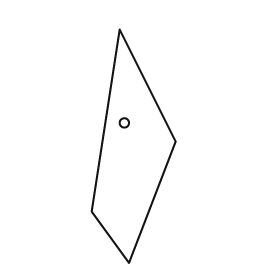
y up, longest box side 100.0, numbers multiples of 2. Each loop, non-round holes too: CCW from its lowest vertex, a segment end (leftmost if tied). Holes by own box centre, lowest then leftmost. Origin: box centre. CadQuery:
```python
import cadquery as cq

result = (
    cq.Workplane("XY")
    .moveTo(-2.0, -50.0)
    .lineTo(18.0, 2.0)
    .lineTo(-6.0, 50.0)
    .lineTo(-18.0, -28.0)
    .close()
    .moveTo(-4.0, 10.0)
    .circle(2.0)
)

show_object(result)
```